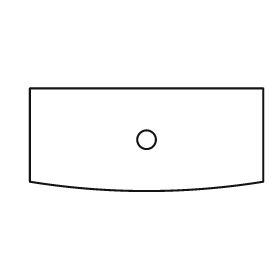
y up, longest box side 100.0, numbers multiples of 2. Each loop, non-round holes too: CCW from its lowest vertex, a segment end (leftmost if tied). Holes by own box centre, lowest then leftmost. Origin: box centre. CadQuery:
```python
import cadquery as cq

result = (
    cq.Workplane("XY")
    .moveTo(-50.0, -18.0)
    .threePointArc((0.0, -22.0), (50.0, -18.0))
    .lineTo(50.0, 22.0)
    .lineTo(-50.0, 22.0)
    .close()
    .moveTo(0.0, 0.0)
    .circle(4.0)
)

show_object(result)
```